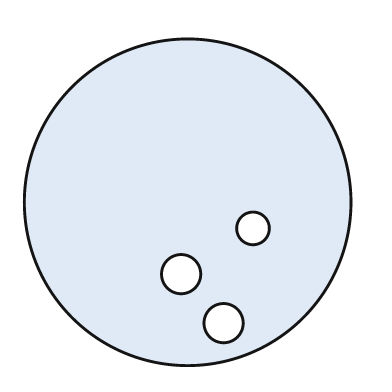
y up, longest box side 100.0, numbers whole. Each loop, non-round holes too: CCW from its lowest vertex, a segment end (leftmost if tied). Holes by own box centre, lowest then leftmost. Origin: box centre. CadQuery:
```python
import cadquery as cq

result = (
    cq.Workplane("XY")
    .moveTo(0.0, 0.0)
    .circle(50.0)
    .moveTo(11.0, -37.0)
    .circle(6.0)
    .moveTo(-2.0, -22.0)
    .circle(6.0)
    .moveTo(20.0, -8.0)
    .circle(5.0)
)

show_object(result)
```